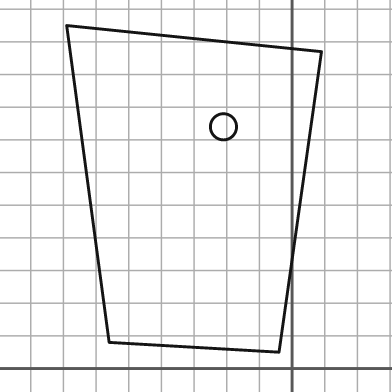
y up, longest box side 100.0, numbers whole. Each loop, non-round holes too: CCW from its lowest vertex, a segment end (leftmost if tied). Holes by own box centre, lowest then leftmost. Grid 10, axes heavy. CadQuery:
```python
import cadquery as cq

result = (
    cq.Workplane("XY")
    .moveTo(-4.0, 5.0)
    .lineTo(9.0, 97.0)
    .lineTo(-69.0, 105.0)
    .lineTo(-56.0, 8.0)
    .close()
    .moveTo(-21.0, 74.0)
    .circle(4.0)
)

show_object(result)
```